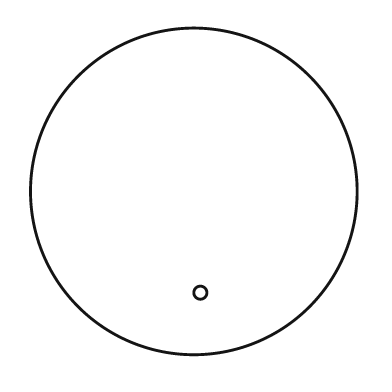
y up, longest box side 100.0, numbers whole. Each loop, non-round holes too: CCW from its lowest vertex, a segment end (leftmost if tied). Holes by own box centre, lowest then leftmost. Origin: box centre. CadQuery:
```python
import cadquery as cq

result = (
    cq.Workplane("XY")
    .moveTo(0.0, 0.0)
    .circle(50.0)
    .moveTo(2.0, -31.0)
    .circle(2.0)
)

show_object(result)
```